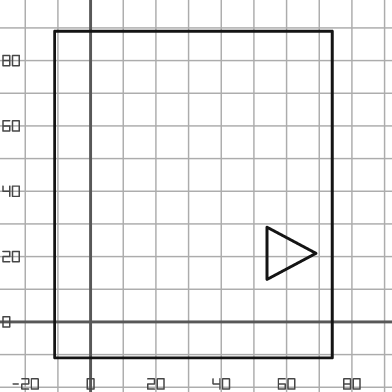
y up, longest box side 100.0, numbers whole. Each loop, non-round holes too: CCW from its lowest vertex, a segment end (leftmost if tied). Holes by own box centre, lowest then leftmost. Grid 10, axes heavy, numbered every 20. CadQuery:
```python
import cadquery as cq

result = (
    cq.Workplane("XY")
    .moveTo(-11.0, -11.0)
    .lineTo(74.0, -11.0)
    .lineTo(74.0, 89.0)
    .lineTo(-11.0, 89.0)
    .close()
    .moveTo(54.0, 13.0)
    .lineTo(69.0, 21.0)
    .lineTo(54.0, 29.0)
    .close()
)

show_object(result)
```